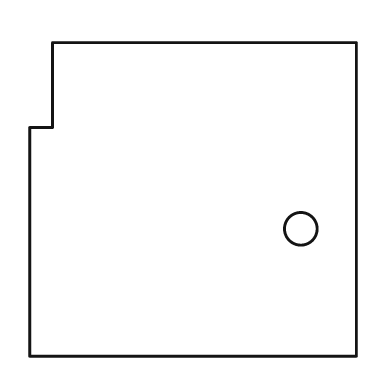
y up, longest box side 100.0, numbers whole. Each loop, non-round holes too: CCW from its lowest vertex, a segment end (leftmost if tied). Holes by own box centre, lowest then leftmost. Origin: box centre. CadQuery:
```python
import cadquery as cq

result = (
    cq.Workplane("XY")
    .moveTo(-50.0, -48.0)
    .lineTo(50.0, -48.0)
    .lineTo(50.0, 48.0)
    .lineTo(-43.0, 48.0)
    .lineTo(-43.0, 22.0)
    .lineTo(-50.0, 22.0)
    .close()
    .moveTo(33.0, -9.0)
    .circle(5.0)
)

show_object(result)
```